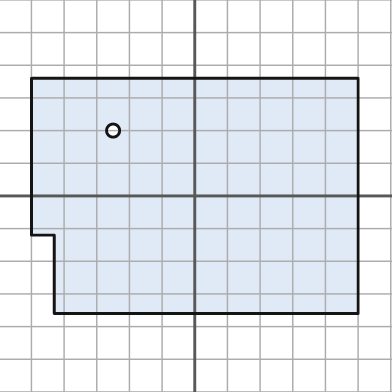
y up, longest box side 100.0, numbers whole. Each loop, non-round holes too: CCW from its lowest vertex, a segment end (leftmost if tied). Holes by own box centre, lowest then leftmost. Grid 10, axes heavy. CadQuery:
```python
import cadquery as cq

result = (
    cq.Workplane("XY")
    .moveTo(-43.0, -36.0)
    .lineTo(50.0, -36.0)
    .lineTo(50.0, 36.0)
    .lineTo(-50.0, 36.0)
    .lineTo(-50.0, -12.0)
    .lineTo(-43.0, -12.0)
    .close()
    .moveTo(-25.0, 20.0)
    .circle(2.0)
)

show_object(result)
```